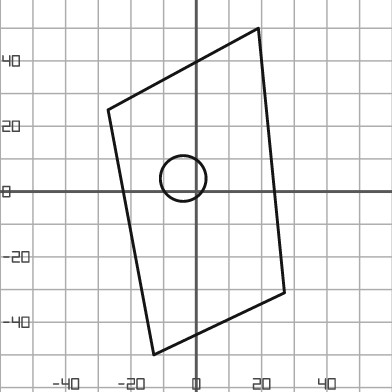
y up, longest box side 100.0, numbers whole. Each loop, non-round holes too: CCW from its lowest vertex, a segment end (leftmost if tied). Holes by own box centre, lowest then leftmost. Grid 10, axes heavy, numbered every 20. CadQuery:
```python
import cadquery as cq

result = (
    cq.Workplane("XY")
    .moveTo(-13.0, -50.0)
    .lineTo(27.0, -31.0)
    .lineTo(19.0, 50.0)
    .lineTo(-27.0, 25.0)
    .close()
    .moveTo(-4.0, 4.0)
    .circle(7.0)
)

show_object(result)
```